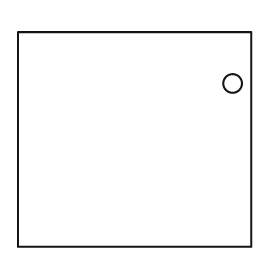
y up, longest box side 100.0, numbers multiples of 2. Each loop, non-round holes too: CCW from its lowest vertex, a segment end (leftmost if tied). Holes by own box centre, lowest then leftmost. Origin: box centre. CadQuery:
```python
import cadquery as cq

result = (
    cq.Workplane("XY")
    .moveTo(-50.0, -46.0)
    .lineTo(50.0, -46.0)
    .lineTo(50.0, 46.0)
    .lineTo(-50.0, 46.0)
    .close()
    .moveTo(42.0, 24.0)
    .circle(4.0)
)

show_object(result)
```